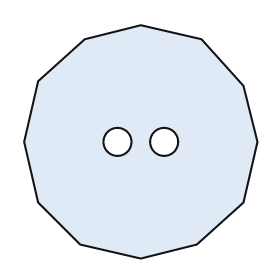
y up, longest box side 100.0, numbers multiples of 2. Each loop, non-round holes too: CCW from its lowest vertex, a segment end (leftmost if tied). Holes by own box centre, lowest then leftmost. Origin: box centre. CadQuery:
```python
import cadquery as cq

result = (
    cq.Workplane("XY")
    .moveTo(0.0, -50.0)
    .lineTo(24.0, -44.0)
    .lineTo(44.0, -26.0)
    .lineTo(50.0, 0.0)
    .lineTo(44.0, 24.0)
    .lineTo(26.0, 44.0)
    .lineTo(0.0, 50.0)
    .lineTo(-24.0, 44.0)
    .lineTo(-44.0, 26.0)
    .lineTo(-50.0, 0.0)
    .lineTo(-44.0, -26.0)
    .lineTo(-26.0, -44.0)
    .close()
    .moveTo(-10.0, 0.0)
    .circle(6.0)
    .moveTo(10.0, 0.0)
    .circle(6.0)
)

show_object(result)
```